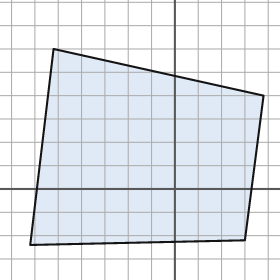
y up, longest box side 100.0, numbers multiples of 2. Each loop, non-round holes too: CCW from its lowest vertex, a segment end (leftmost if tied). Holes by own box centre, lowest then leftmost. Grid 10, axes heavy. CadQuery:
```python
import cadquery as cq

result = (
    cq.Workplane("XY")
    .moveTo(-62.0, -24.0)
    .lineTo(30.0, -22.0)
    .lineTo(38.0, 40.0)
    .lineTo(-52.0, 60.0)
    .close()
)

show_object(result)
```